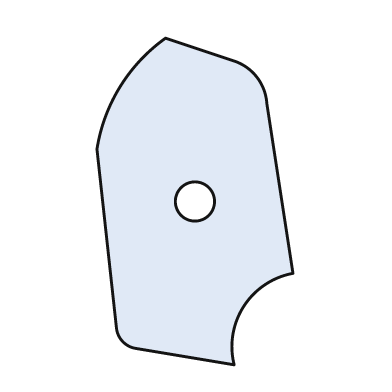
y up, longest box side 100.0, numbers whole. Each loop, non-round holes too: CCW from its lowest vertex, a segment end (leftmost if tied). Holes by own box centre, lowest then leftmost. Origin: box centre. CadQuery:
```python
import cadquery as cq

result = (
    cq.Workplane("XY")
    .moveTo(12.0, -50.0)
    .threePointArc((15.0, -32.0), (30.0, -22.0))
    .lineTo(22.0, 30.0)
    .threePointArc((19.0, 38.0), (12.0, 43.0))
    .lineTo(-9.0, 50.0)
    .threePointArc((-23.0, 35.0), (-30.0, 16.0))
    .lineTo(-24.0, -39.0)
    .threePointArc((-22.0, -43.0), (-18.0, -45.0))
    .close()
    .moveTo(0.0, 0.0)
    .circle(6.0)
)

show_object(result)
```